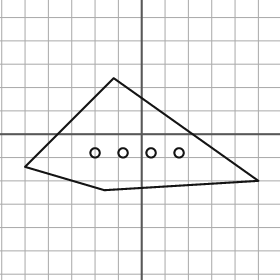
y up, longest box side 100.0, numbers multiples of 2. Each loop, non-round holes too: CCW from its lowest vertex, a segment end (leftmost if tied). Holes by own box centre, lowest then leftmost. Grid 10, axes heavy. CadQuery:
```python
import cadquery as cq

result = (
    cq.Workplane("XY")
    .moveTo(-16.0, -24.0)
    .lineTo(50.0, -20.0)
    .lineTo(-12.0, 24.0)
    .lineTo(-50.0, -14.0)
    .close()
    .moveTo(-20.0, -8.0)
    .circle(2.0)
    .moveTo(-8.0, -8.0)
    .circle(2.0)
    .moveTo(4.0, -8.0)
    .circle(2.0)
    .moveTo(16.0, -8.0)
    .circle(2.0)
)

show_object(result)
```